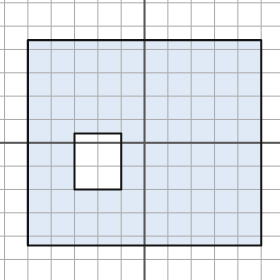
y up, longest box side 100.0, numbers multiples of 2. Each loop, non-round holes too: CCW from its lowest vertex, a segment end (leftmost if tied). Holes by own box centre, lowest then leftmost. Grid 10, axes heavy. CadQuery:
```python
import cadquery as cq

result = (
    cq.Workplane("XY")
    .moveTo(-50.0, -44.0)
    .lineTo(50.0, -44.0)
    .lineTo(50.0, 44.0)
    .lineTo(-50.0, 44.0)
    .close()
    .moveTo(-30.0, -20.0)
    .lineTo(-10.0, -20.0)
    .lineTo(-10.0, 4.0)
    .lineTo(-30.0, 4.0)
    .close()
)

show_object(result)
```